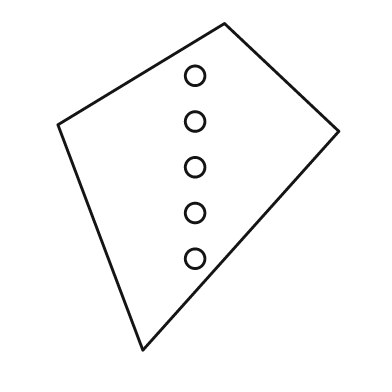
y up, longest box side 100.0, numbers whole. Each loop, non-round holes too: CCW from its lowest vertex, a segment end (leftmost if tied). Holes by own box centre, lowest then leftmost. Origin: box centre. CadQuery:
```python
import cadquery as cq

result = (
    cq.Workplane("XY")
    .moveTo(-17.0, -50.0)
    .lineTo(43.0, 17.0)
    .lineTo(8.0, 50.0)
    .lineTo(-43.0, 19.0)
    .close()
    .moveTo(-1.0, -22.0)
    .circle(3.0)
    .moveTo(-1.0, -8.0)
    .circle(3.0)
    .moveTo(-1.0, 6.0)
    .circle(3.0)
    .moveTo(-1.0, 20.0)
    .circle(3.0)
    .moveTo(-1.0, 34.0)
    .circle(3.0)
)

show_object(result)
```